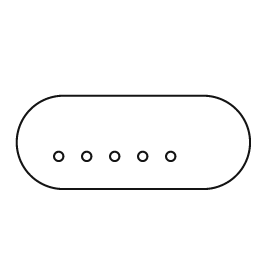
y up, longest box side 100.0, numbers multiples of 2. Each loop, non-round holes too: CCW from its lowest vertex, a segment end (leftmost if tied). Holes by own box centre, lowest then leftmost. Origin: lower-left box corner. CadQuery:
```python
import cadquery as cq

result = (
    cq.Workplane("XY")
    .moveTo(20.0, 0.0)
    .lineTo(80.0, 0.0)
    .threePointArc((100.0, 20.0), (80.0, 40.0))
    .lineTo(20.0, 40.0)
    .threePointArc((0.0, 20.0), (20.0, 0.0))
    .close()
    .moveTo(18.0, 14.0)
    .circle(2.0)
    .moveTo(30.0, 14.0)
    .circle(2.0)
    .moveTo(42.0, 14.0)
    .circle(2.0)
    .moveTo(54.0, 14.0)
    .circle(2.0)
    .moveTo(66.0, 14.0)
    .circle(2.0)
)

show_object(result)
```